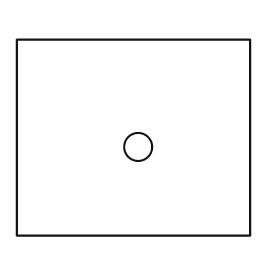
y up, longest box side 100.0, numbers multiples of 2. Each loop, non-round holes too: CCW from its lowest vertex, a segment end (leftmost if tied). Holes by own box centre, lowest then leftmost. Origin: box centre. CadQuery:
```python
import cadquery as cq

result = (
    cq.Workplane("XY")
    .moveTo(-50.0, -42.0)
    .lineTo(50.0, -42.0)
    .lineTo(50.0, 42.0)
    .lineTo(-50.0, 42.0)
    .close()
    .moveTo(2.0, -4.0)
    .circle(6.0)
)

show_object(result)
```